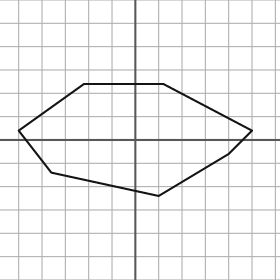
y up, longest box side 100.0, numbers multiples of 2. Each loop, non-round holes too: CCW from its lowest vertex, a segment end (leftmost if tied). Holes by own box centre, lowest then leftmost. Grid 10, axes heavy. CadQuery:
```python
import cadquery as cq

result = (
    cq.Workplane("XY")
    .moveTo(10.0, -24.0)
    .lineTo(40.0, -6.0)
    .lineTo(50.0, 4.0)
    .lineTo(12.0, 24.0)
    .lineTo(-22.0, 24.0)
    .lineTo(-50.0, 4.0)
    .lineTo(-36.0, -14.0)
    .close()
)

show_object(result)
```